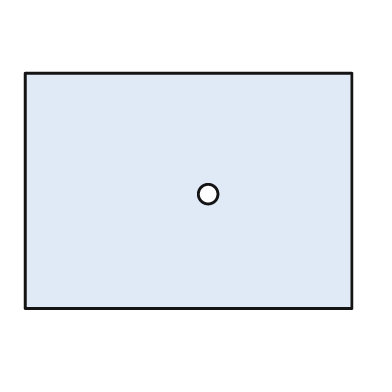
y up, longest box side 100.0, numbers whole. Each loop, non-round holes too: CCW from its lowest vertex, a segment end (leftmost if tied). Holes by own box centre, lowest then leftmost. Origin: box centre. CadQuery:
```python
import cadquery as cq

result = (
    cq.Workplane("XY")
    .moveTo(-50.0, -36.0)
    .lineTo(50.0, -36.0)
    .lineTo(50.0, 36.0)
    .lineTo(-50.0, 36.0)
    .close()
    .moveTo(6.0, -1.0)
    .circle(3.0)
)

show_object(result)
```